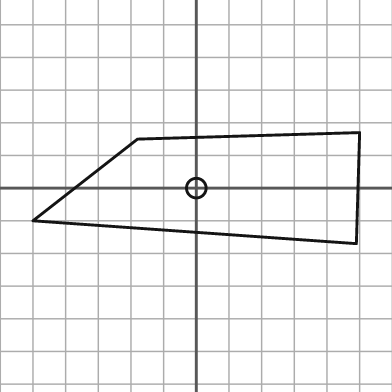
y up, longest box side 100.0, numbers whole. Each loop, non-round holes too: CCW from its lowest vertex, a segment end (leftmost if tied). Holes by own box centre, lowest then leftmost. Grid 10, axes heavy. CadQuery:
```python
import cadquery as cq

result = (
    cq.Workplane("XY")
    .moveTo(49.0, -17.0)
    .lineTo(50.0, 17.0)
    .lineTo(-18.0, 15.0)
    .lineTo(-50.0, -10.0)
    .close()
    .moveTo(0.0, 0.0)
    .circle(3.0)
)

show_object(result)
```